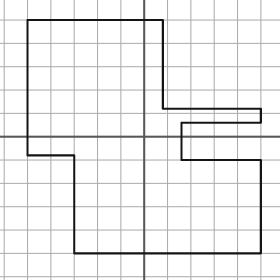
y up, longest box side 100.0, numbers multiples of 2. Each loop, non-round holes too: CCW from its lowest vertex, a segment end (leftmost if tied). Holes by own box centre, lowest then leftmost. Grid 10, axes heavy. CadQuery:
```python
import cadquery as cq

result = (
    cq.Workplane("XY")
    .moveTo(-30.0, -50.0)
    .lineTo(50.0, -50.0)
    .lineTo(50.0, -10.0)
    .lineTo(16.0, -10.0)
    .lineTo(16.0, 6.0)
    .lineTo(50.0, 6.0)
    .lineTo(50.0, 12.0)
    .lineTo(8.0, 12.0)
    .lineTo(8.0, 50.0)
    .lineTo(-50.0, 50.0)
    .lineTo(-50.0, -8.0)
    .lineTo(-30.0, -8.0)
    .close()
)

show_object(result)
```